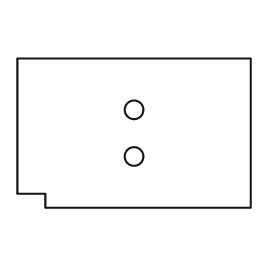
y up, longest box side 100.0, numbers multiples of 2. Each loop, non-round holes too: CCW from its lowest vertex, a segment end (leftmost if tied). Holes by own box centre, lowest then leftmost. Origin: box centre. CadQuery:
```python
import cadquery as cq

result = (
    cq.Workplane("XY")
    .moveTo(-38.0, -32.0)
    .lineTo(50.0, -32.0)
    .lineTo(50.0, 32.0)
    .lineTo(-50.0, 32.0)
    .lineTo(-50.0, -26.0)
    .lineTo(-38.0, -26.0)
    .close()
    .moveTo(0.0, -10.0)
    .circle(4.0)
    .moveTo(0.0, 10.0)
    .circle(4.0)
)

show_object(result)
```